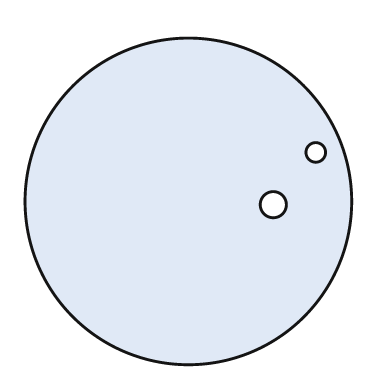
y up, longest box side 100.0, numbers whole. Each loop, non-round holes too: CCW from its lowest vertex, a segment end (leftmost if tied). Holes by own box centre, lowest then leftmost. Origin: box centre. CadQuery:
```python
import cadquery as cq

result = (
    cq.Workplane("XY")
    .moveTo(0.0, 0.0)
    .circle(50.0)
    .moveTo(26.0, -1.0)
    .circle(4.0)
    .moveTo(39.0, 15.0)
    .circle(3.0)
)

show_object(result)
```